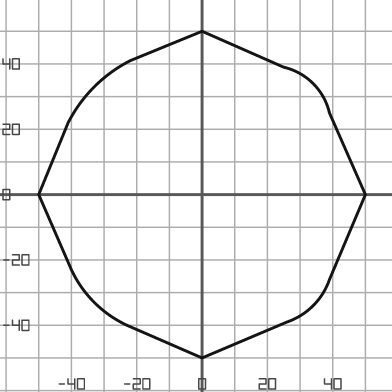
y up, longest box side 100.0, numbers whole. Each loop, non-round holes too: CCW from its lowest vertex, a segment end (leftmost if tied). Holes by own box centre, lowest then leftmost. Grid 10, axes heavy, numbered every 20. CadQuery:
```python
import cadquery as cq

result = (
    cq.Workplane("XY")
    .moveTo(0.0, -50.0)
    .lineTo(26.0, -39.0)
    .threePointArc((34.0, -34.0), (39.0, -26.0))
    .lineTo(50.0, 0.0)
    .lineTo(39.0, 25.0)
    .threePointArc((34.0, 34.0), (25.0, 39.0))
    .lineTo(0.0, 50.0)
    .lineTo(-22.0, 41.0)
    .threePointArc((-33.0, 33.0), (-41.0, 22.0))
    .lineTo(-50.0, 0.0)
    .lineTo(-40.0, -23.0)
    .threePointArc((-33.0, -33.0), (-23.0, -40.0))
    .close()
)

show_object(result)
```